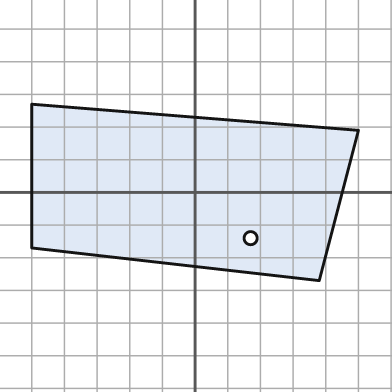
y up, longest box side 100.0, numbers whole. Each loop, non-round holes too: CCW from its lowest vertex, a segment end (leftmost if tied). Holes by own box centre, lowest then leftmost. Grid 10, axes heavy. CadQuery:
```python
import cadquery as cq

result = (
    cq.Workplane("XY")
    .moveTo(38.0, -27.0)
    .lineTo(50.0, 19.0)
    .lineTo(-50.0, 27.0)
    .lineTo(-50.0, -17.0)
    .close()
    .moveTo(17.0, -14.0)
    .circle(2.0)
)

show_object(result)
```